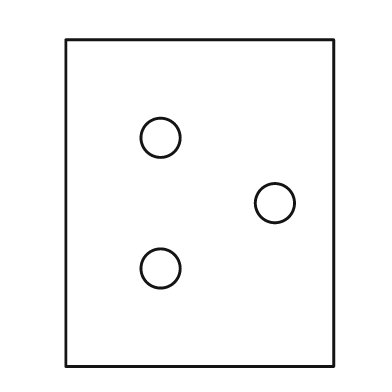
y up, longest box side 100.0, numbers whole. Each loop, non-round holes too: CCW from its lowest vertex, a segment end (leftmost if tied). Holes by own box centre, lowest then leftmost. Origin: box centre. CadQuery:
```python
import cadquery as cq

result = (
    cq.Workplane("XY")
    .moveTo(-41.0, -50.0)
    .lineTo(41.0, -50.0)
    .lineTo(41.0, 50.0)
    .lineTo(-41.0, 50.0)
    .close()
    .moveTo(-12.0, -20.0)
    .circle(6.0)
    .moveTo(23.0, 0.0)
    .circle(6.0)
    .moveTo(-12.0, 20.0)
    .circle(6.0)
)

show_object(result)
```